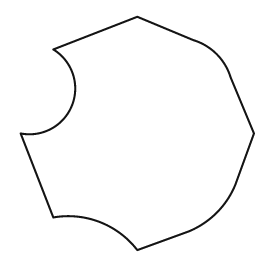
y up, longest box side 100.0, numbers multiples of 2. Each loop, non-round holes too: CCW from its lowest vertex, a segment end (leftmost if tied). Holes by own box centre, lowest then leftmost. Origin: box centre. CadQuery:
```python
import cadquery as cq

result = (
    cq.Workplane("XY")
    .moveTo(0.0, -50.0)
    .lineTo(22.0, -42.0)
    .threePointArc((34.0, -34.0), (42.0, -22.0))
    .lineTo(50.0, 0.0)
    .lineTo(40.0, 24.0)
    .threePointArc((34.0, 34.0), (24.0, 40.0))
    .lineTo(0.0, 50.0)
    .lineTo(-36.0, 36.0)
    .threePointArc((-28.0, 12.0), (-50.0, 0.0))
    .lineTo(-36.0, -36.0)
    .threePointArc((-16.0, -38.0), (0.0, -50.0))
    .close()
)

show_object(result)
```